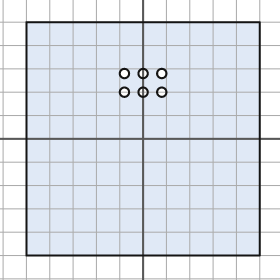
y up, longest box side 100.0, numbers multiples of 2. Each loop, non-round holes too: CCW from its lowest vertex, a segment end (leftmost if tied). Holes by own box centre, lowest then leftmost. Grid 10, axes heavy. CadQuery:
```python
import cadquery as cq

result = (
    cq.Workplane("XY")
    .moveTo(-50.0, -50.0)
    .lineTo(50.0, -50.0)
    .lineTo(50.0, 50.0)
    .lineTo(-50.0, 50.0)
    .close()
    .moveTo(-8.0, 20.0)
    .circle(2.0)
    .moveTo(0.0, 20.0)
    .circle(2.0)
    .moveTo(8.0, 20.0)
    .circle(2.0)
    .moveTo(-8.0, 28.0)
    .circle(2.0)
    .moveTo(0.0, 28.0)
    .circle(2.0)
    .moveTo(8.0, 28.0)
    .circle(2.0)
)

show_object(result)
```